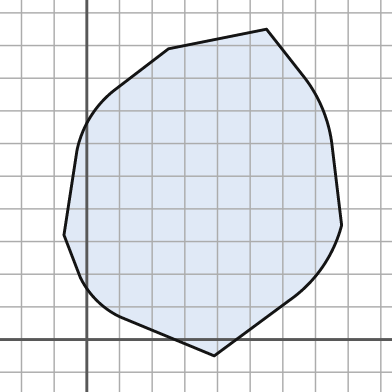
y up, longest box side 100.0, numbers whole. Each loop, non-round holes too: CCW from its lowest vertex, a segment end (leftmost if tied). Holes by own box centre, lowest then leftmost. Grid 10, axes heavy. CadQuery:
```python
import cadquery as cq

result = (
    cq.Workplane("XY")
    .moveTo(39.0, -5.0)
    .lineTo(62.0, 12.0)
    .threePointArc((72.0, 22.0), (78.0, 35.0))
    .lineTo(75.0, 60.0)
    .threePointArc((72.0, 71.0), (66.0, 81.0))
    .lineTo(55.0, 95.0)
    .lineTo(25.0, 89.0)
    .lineTo(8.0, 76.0)
    .threePointArc((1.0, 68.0), (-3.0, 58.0))
    .lineTo(-7.0, 32.0)
    .lineTo(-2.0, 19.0)
    .threePointArc((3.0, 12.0), (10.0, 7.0))
    .close()
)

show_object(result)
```